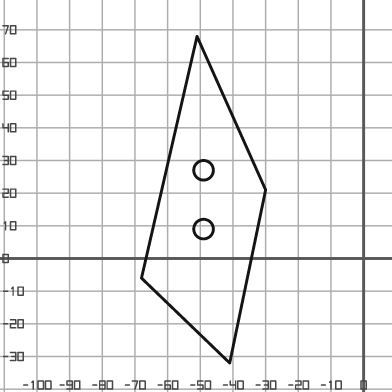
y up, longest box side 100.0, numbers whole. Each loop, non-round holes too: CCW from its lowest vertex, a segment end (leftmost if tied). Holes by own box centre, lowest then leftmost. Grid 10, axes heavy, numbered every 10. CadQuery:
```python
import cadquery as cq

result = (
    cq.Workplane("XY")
    .moveTo(-41.0, -32.0)
    .lineTo(-30.0, 21.0)
    .lineTo(-51.0, 68.0)
    .lineTo(-68.0, -6.0)
    .close()
    .moveTo(-49.0, 9.0)
    .circle(3.0)
    .moveTo(-49.0, 27.0)
    .circle(3.0)
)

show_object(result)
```